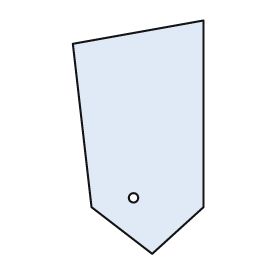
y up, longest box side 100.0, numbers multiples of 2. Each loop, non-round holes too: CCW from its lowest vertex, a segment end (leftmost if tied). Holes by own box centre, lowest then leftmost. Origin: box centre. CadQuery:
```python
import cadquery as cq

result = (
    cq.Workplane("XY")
    .moveTo(6.0, -50.0)
    .lineTo(28.0, -30.0)
    .lineTo(28.0, 50.0)
    .lineTo(-28.0, 40.0)
    .lineTo(-20.0, -30.0)
    .close()
    .moveTo(-2.0, -26.0)
    .circle(2.0)
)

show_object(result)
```